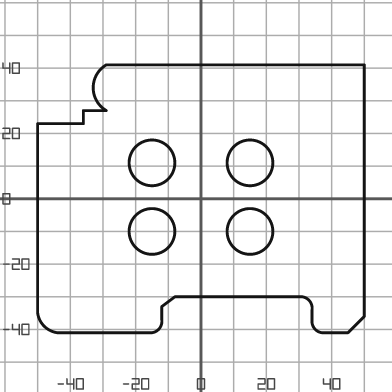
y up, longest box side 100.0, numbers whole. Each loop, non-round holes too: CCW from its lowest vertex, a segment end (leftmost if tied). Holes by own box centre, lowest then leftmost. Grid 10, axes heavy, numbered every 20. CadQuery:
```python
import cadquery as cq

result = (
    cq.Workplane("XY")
    .moveTo(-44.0, -41.0)
    .lineTo(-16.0, -41.0)
    .threePointArc((-13.0, -40.0), (-12.0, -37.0))
    .lineTo(-12.0, -33.0)
    .lineTo(-8.0, -30.0)
    .lineTo(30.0, -30.0)
    .threePointArc((33.0, -31.0), (34.0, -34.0))
    .lineTo(34.0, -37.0)
    .threePointArc((35.0, -40.0), (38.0, -41.0))
    .lineTo(45.0, -41.0)
    .lineTo(50.0, -36.0)
    .lineTo(50.0, 41.0)
    .lineTo(-29.0, 41.0)
    .threePointArc((-33.0, 34.0), (-29.0, 27.0))
    .lineTo(-36.0, 27.0)
    .lineTo(-36.0, 23.0)
    .lineTo(-50.0, 23.0)
    .lineTo(-50.0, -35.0)
    .threePointArc((-48.0, -39.0), (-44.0, -41.0))
    .close()
    .moveTo(-15.0, -10.0)
    .circle(7.0)
    .moveTo(15.0, -10.0)
    .circle(7.0)
    .moveTo(-15.0, 11.0)
    .circle(7.0)
    .moveTo(15.0, 11.0)
    .circle(7.0)
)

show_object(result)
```